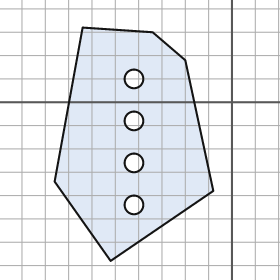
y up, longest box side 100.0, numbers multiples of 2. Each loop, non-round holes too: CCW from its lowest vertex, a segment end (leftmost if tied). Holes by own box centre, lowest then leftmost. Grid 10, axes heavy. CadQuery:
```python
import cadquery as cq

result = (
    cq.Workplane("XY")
    .moveTo(-52.0, -68.0)
    .lineTo(-8.0, -38.0)
    .lineTo(-20.0, 18.0)
    .lineTo(-34.0, 30.0)
    .lineTo(-64.0, 32.0)
    .lineTo(-76.0, -34.0)
    .close()
    .moveTo(-42.0, -44.0)
    .circle(4.0)
    .moveTo(-42.0, -26.0)
    .circle(4.0)
    .moveTo(-42.0, -8.0)
    .circle(4.0)
    .moveTo(-42.0, 10.0)
    .circle(4.0)
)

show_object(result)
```